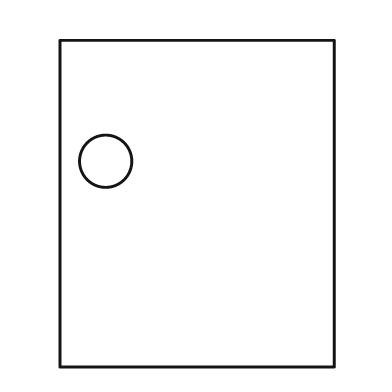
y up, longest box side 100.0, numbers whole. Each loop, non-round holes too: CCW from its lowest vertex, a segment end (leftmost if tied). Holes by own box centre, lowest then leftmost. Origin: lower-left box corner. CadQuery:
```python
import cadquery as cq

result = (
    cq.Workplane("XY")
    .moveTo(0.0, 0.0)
    .lineTo(84.0, 0.0)
    .lineTo(84.0, 100.0)
    .lineTo(0.0, 100.0)
    .close()
    .moveTo(14.0, 63.0)
    .circle(8.0)
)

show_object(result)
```